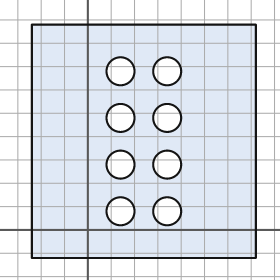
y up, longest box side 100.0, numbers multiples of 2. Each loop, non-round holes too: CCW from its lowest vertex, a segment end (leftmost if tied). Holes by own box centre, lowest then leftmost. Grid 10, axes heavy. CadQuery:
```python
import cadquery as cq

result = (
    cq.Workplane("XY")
    .moveTo(-24.0, -12.0)
    .lineTo(72.0, -12.0)
    .lineTo(72.0, 88.0)
    .lineTo(-24.0, 88.0)
    .close()
    .moveTo(14.0, 8.0)
    .circle(6.0)
    .moveTo(34.0, 8.0)
    .circle(6.0)
    .moveTo(14.0, 28.0)
    .circle(6.0)
    .moveTo(34.0, 28.0)
    .circle(6.0)
    .moveTo(14.0, 48.0)
    .circle(6.0)
    .moveTo(34.0, 48.0)
    .circle(6.0)
    .moveTo(14.0, 68.0)
    .circle(6.0)
    .moveTo(34.0, 68.0)
    .circle(6.0)
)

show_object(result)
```